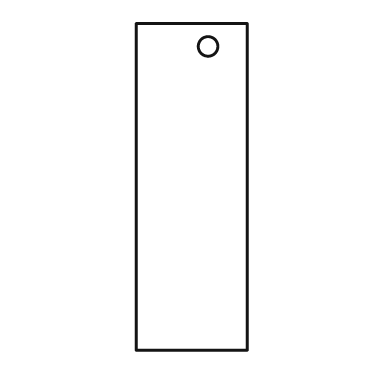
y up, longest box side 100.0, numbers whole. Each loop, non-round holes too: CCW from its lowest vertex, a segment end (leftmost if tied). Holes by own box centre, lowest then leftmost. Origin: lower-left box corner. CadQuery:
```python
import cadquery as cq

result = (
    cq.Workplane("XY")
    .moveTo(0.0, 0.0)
    .lineTo(34.0, 0.0)
    .lineTo(34.0, 100.0)
    .lineTo(0.0, 100.0)
    .close()
    .moveTo(22.0, 93.0)
    .circle(3.0)
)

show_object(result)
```